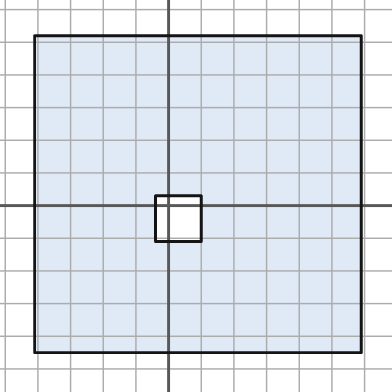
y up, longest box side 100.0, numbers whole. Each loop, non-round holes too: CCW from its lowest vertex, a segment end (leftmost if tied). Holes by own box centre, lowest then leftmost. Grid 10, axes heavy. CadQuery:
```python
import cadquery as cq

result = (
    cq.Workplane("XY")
    .moveTo(-41.0, -45.0)
    .lineTo(59.0, -45.0)
    .lineTo(59.0, 52.0)
    .lineTo(-41.0, 52.0)
    .close()
    .moveTo(-4.0, -11.0)
    .lineTo(10.0, -11.0)
    .lineTo(10.0, 3.0)
    .lineTo(-4.0, 3.0)
    .close()
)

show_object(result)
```